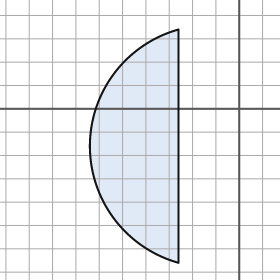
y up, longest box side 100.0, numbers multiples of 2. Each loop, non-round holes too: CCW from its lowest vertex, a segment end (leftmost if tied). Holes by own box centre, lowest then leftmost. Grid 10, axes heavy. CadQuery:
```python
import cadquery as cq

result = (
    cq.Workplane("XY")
    .moveTo(-26.0, -66.0)
    .lineTo(-26.0, 34.0)
    .threePointArc((-64.0, -16.0), (-26.0, -66.0))
    .close()
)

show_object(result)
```